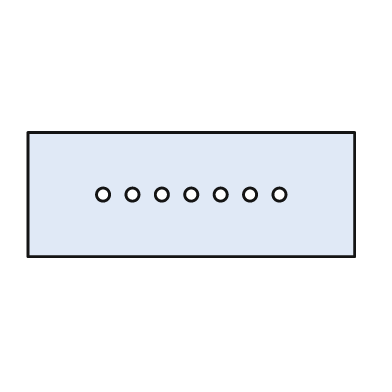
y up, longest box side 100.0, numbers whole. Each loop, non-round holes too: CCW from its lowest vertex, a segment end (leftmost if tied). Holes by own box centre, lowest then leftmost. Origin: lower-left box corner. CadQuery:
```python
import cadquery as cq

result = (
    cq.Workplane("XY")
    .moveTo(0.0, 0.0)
    .lineTo(100.0, 0.0)
    .lineTo(100.0, 38.0)
    .lineTo(0.0, 38.0)
    .close()
    .moveTo(23.0, 19.0)
    .circle(2.0)
    .moveTo(32.0, 19.0)
    .circle(2.0)
    .moveTo(41.0, 19.0)
    .circle(2.0)
    .moveTo(50.0, 19.0)
    .circle(2.0)
    .moveTo(59.0, 19.0)
    .circle(2.0)
    .moveTo(68.0, 19.0)
    .circle(2.0)
    .moveTo(77.0, 19.0)
    .circle(2.0)
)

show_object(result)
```